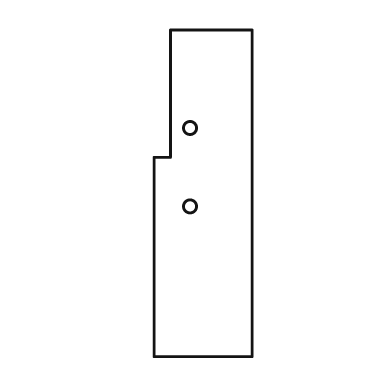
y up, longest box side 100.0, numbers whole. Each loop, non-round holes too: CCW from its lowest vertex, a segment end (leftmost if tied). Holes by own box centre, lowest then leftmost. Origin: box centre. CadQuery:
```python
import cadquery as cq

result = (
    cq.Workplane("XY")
    .moveTo(-15.0, -50.0)
    .lineTo(15.0, -50.0)
    .lineTo(15.0, 50.0)
    .lineTo(-10.0, 50.0)
    .lineTo(-10.0, 11.0)
    .lineTo(-15.0, 11.0)
    .close()
    .moveTo(-4.0, -4.0)
    .circle(2.0)
    .moveTo(-4.0, 20.0)
    .circle(2.0)
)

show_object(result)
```